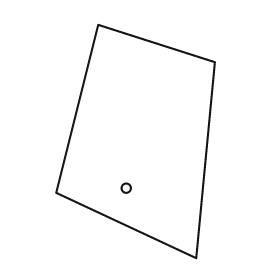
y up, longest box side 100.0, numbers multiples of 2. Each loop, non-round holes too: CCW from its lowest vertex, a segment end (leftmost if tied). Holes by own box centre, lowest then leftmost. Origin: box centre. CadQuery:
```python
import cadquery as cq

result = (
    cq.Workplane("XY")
    .moveTo(26.0, -50.0)
    .lineTo(34.0, 34.0)
    .lineTo(-16.0, 50.0)
    .lineTo(-34.0, -22.0)
    .close()
    .moveTo(-4.0, -20.0)
    .circle(2.0)
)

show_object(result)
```